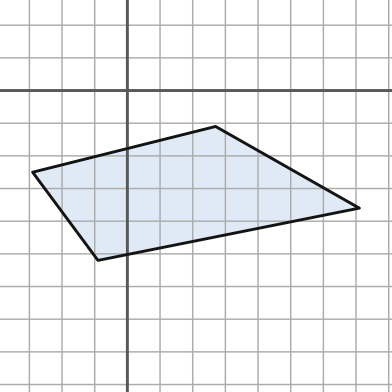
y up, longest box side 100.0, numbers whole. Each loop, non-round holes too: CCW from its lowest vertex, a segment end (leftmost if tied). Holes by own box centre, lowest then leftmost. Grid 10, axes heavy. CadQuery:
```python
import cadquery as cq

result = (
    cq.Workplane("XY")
    .moveTo(-9.0, -52.0)
    .lineTo(71.0, -36.0)
    .lineTo(27.0, -11.0)
    .lineTo(-29.0, -25.0)
    .close()
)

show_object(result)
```